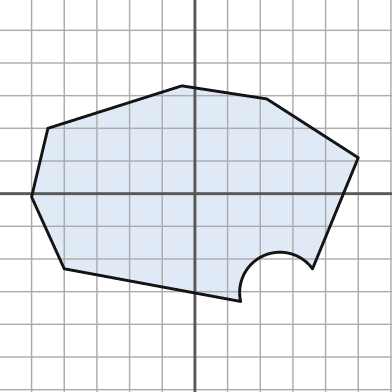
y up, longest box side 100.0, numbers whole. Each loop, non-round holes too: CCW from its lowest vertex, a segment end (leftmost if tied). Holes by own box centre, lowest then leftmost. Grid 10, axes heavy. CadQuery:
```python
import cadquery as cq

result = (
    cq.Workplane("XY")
    .moveTo(14.0, -33.0)
    .threePointArc((21.0, -19.0), (36.0, -23.0))
    .lineTo(50.0, 11.0)
    .lineTo(22.0, 29.0)
    .lineTo(-4.0, 33.0)
    .lineTo(-45.0, 20.0)
    .lineTo(-50.0, -1.0)
    .lineTo(-40.0, -23.0)
    .close()
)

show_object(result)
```